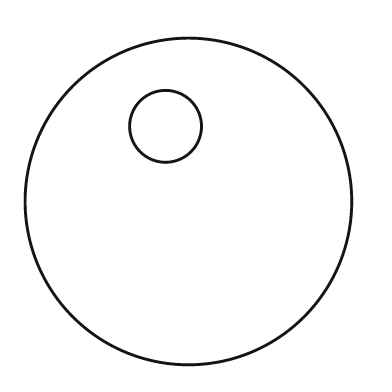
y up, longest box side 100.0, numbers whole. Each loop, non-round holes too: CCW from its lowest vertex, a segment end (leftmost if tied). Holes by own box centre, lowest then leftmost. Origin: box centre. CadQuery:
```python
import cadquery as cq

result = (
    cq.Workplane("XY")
    .moveTo(0.0, 0.0)
    .circle(50.0)
    .moveTo(-7.0, 23.0)
    .circle(11.0)
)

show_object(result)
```